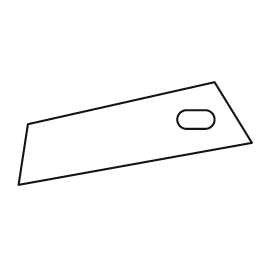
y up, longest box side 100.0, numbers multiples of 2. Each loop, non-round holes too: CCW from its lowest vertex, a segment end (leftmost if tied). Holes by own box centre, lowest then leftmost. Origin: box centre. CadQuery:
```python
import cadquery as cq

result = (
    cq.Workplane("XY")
    .moveTo(-50.0, -22.0)
    .lineTo(50.0, -4.0)
    .lineTo(34.0, 22.0)
    .lineTo(-46.0, 4.0)
    .close()
    .moveTo(22.0, 2.0)
    .lineTo(30.0, 2.0)
    .threePointArc((34.0, 6.0), (30.0, 10.0))
    .lineTo(22.0, 10.0)
    .threePointArc((18.0, 6.0), (22.0, 2.0))
    .close()
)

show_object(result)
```